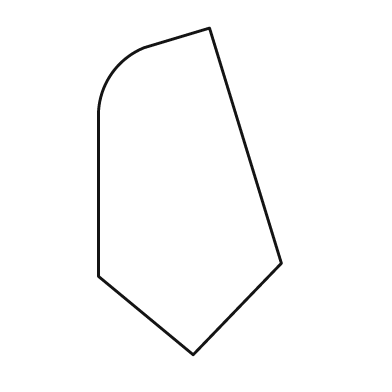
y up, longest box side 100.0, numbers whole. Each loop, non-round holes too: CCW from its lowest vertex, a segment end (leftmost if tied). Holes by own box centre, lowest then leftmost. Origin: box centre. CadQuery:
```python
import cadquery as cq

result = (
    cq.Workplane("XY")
    .moveTo(1.0, -50.0)
    .lineTo(28.0, -22.0)
    .lineTo(6.0, 50.0)
    .lineTo(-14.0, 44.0)
    .threePointArc((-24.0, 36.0), (-28.0, 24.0))
    .lineTo(-28.0, -26.0)
    .close()
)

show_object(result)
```